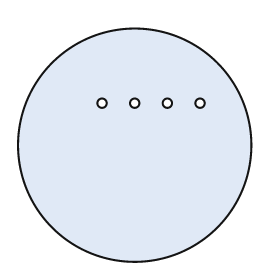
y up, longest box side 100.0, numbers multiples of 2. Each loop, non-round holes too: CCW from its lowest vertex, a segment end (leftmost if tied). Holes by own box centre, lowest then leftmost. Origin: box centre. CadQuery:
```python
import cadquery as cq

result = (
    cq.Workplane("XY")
    .moveTo(0.0, 0.0)
    .circle(50.0)
    .moveTo(-14.0, 18.0)
    .circle(2.0)
    .moveTo(0.0, 18.0)
    .circle(2.0)
    .moveTo(14.0, 18.0)
    .circle(2.0)
    .moveTo(28.0, 18.0)
    .circle(2.0)
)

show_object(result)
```